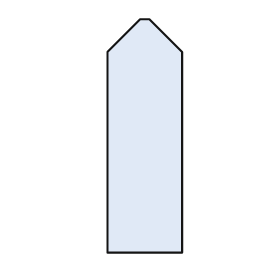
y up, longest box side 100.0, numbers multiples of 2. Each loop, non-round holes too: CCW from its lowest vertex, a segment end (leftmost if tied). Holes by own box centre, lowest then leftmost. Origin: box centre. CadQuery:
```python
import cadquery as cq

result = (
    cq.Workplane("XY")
    .moveTo(-16.0, -50.0)
    .lineTo(16.0, -50.0)
    .lineTo(16.0, 36.0)
    .lineTo(2.0, 50.0)
    .lineTo(-2.0, 50.0)
    .lineTo(-16.0, 36.0)
    .close()
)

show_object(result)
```